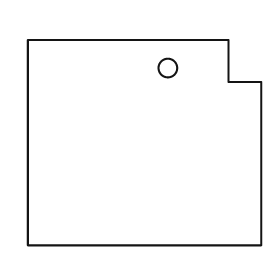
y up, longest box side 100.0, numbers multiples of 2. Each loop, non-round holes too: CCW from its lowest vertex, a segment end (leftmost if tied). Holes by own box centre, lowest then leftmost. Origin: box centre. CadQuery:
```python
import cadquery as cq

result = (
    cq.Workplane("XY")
    .moveTo(-50.0, -44.0)
    .lineTo(50.0, -44.0)
    .lineTo(50.0, 26.0)
    .lineTo(36.0, 26.0)
    .lineTo(36.0, 44.0)
    .lineTo(-50.0, 44.0)
    .close()
    .moveTo(10.0, 32.0)
    .circle(4.0)
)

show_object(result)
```